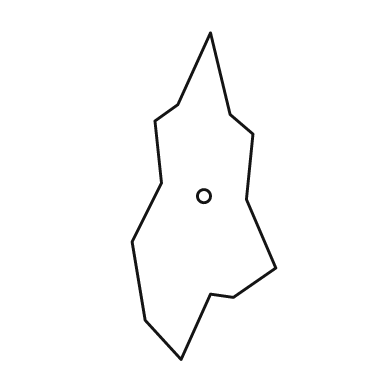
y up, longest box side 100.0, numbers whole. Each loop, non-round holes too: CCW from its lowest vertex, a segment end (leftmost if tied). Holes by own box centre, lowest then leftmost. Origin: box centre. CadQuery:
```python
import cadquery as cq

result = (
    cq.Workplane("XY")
    .moveTo(-7.0, -50.0)
    .lineTo(2.0, -30.0)
    .lineTo(9.0, -31.0)
    .lineTo(22.0, -22.0)
    .lineTo(13.0, -1.0)
    .lineTo(15.0, 19.0)
    .lineTo(8.0, 25.0)
    .lineTo(2.0, 50.0)
    .lineTo(-8.0, 28.0)
    .lineTo(-15.0, 23.0)
    .lineTo(-13.0, 4.0)
    .lineTo(-22.0, -14.0)
    .lineTo(-18.0, -38.0)
    .close()
    .moveTo(0.0, 0.0)
    .circle(2.0)
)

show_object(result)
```